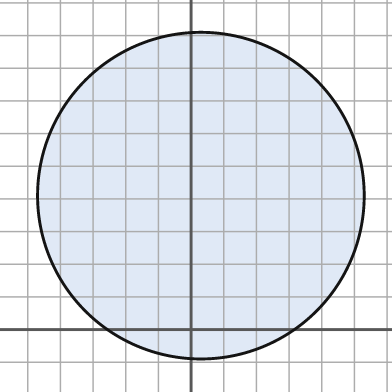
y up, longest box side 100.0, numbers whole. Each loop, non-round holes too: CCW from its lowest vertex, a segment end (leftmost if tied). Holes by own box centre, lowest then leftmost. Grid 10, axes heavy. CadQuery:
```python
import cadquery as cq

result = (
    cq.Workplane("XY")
    .moveTo(3.0, 41.0)
    .circle(50.0)
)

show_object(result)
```